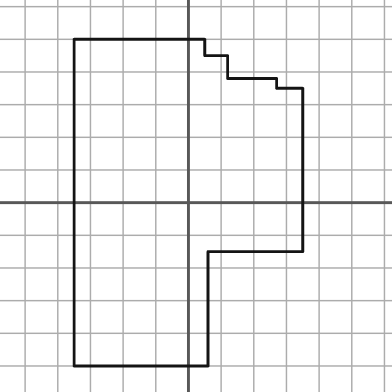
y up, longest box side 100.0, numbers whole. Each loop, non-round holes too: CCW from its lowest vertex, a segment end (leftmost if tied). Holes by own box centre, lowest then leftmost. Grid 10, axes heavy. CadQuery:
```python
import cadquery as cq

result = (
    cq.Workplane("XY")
    .moveTo(-35.0, -50.0)
    .lineTo(6.0, -50.0)
    .lineTo(6.0, -15.0)
    .lineTo(35.0, -15.0)
    .lineTo(35.0, 35.0)
    .lineTo(27.0, 35.0)
    .lineTo(27.0, 38.0)
    .lineTo(12.0, 38.0)
    .lineTo(12.0, 45.0)
    .lineTo(5.0, 45.0)
    .lineTo(5.0, 50.0)
    .lineTo(-35.0, 50.0)
    .close()
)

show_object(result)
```